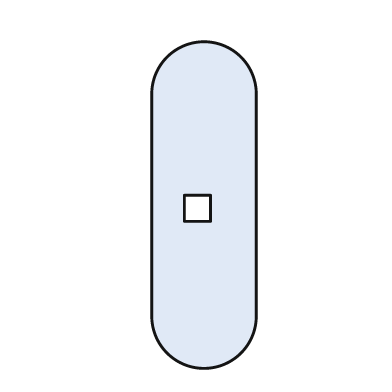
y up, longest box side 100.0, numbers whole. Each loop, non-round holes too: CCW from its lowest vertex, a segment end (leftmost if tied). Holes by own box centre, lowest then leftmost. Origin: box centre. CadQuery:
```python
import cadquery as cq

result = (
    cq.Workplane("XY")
    .moveTo(-16.0, -34.0)
    .threePointArc((0.0, -50.0), (16.0, -34.0))
    .lineTo(16.0, 34.0)
    .threePointArc((0.0, 50.0), (-16.0, 34.0))
    .close()
    .moveTo(-6.0, -5.0)
    .lineTo(2.0, -5.0)
    .lineTo(2.0, 3.0)
    .lineTo(-6.0, 3.0)
    .close()
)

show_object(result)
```